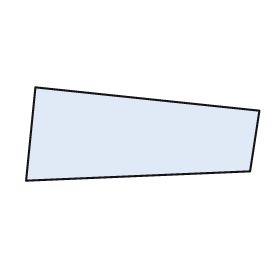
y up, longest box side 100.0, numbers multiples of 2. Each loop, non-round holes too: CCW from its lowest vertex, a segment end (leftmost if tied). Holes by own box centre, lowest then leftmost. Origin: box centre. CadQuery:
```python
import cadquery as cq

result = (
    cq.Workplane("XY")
    .moveTo(-50.0, -20.0)
    .lineTo(46.0, -16.0)
    .lineTo(50.0, 10.0)
    .lineTo(-46.0, 20.0)
    .close()
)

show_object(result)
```